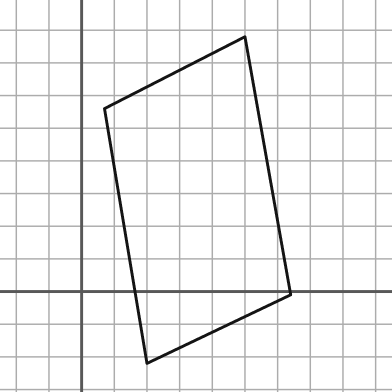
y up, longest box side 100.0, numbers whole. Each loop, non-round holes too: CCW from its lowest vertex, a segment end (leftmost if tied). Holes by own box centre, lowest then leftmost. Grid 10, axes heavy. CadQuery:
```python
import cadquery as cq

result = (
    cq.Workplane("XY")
    .moveTo(20.0, -22.0)
    .lineTo(64.0, -1.0)
    .lineTo(50.0, 78.0)
    .lineTo(7.0, 56.0)
    .close()
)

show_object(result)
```